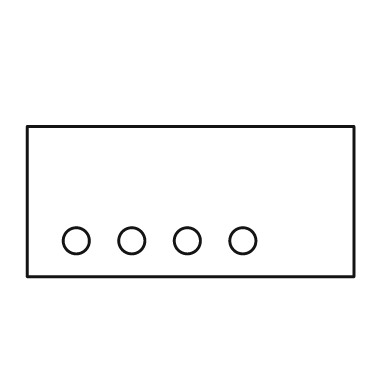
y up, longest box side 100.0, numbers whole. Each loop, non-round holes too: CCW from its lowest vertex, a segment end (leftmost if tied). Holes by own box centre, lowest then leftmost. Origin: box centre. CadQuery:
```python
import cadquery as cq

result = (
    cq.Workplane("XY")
    .moveTo(-50.0, -23.0)
    .lineTo(50.0, -23.0)
    .lineTo(50.0, 23.0)
    .lineTo(-50.0, 23.0)
    .close()
    .moveTo(-35.0, -12.0)
    .circle(4.0)
    .moveTo(-18.0, -12.0)
    .circle(4.0)
    .moveTo(-1.0, -12.0)
    .circle(4.0)
    .moveTo(16.0, -12.0)
    .circle(4.0)
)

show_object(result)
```